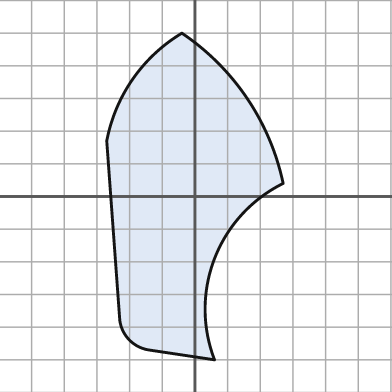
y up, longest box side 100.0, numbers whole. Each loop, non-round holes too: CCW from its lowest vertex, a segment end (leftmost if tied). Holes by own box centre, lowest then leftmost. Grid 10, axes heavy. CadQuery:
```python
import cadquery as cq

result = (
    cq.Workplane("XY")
    .moveTo(6.0, -50.0)
    .threePointArc((6.0, -19.0), (27.0, 4.0))
    .threePointArc((16.0, 30.0), (-4.0, 50.0))
    .threePointArc((-19.0, 36.0), (-27.0, 17.0))
    .lineTo(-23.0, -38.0)
    .threePointArc((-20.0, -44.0), (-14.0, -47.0))
    .close()
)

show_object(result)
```